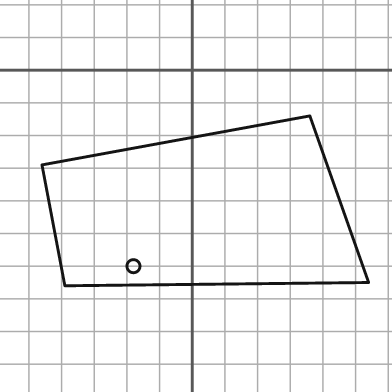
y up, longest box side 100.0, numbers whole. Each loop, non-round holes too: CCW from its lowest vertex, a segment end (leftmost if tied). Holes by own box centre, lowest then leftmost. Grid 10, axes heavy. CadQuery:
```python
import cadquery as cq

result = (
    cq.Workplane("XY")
    .moveTo(-39.0, -66.0)
    .lineTo(54.0, -65.0)
    .lineTo(36.0, -14.0)
    .lineTo(-46.0, -29.0)
    .close()
    .moveTo(-18.0, -60.0)
    .circle(2.0)
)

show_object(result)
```